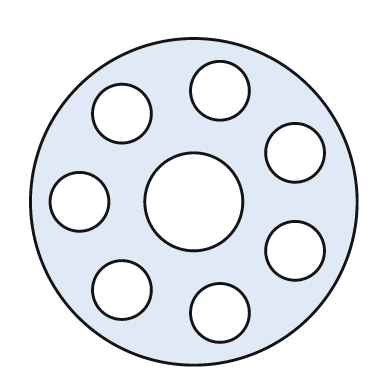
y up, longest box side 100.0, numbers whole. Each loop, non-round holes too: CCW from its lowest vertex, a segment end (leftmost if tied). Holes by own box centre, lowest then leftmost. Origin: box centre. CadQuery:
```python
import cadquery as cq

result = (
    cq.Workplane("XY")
    .moveTo(0.0, 0.0)
    .circle(50.0)
    .moveTo(8.0, -34.0)
    .circle(9.0)
    .moveTo(-22.0, -27.0)
    .circle(9.0)
    .moveTo(31.0, -15.0)
    .circle(9.0)
    .moveTo(-35.0, 0.0)
    .circle(9.0)
    .moveTo(0.0, 0.0)
    .circle(15.0)
    .moveTo(31.0, 15.0)
    .circle(9.0)
    .moveTo(-22.0, 27.0)
    .circle(9.0)
    .moveTo(8.0, 34.0)
    .circle(9.0)
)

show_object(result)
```